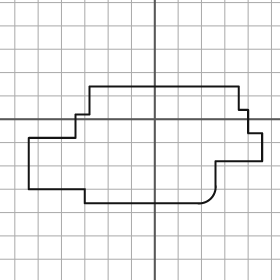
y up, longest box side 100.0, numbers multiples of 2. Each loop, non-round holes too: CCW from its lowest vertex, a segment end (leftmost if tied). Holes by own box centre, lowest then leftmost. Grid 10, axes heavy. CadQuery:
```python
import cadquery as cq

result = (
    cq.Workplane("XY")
    .moveTo(-30.0, -36.0)
    .lineTo(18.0, -36.0)
    .threePointArc((24.0, -34.0), (26.0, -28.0))
    .lineTo(26.0, -18.0)
    .lineTo(46.0, -18.0)
    .lineTo(46.0, -6.0)
    .lineTo(40.0, -6.0)
    .lineTo(40.0, 4.0)
    .lineTo(36.0, 4.0)
    .lineTo(36.0, 14.0)
    .lineTo(-28.0, 14.0)
    .lineTo(-28.0, 2.0)
    .lineTo(-34.0, 2.0)
    .lineTo(-34.0, -8.0)
    .lineTo(-54.0, -8.0)
    .lineTo(-54.0, -30.0)
    .lineTo(-30.0, -30.0)
    .close()
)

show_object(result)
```